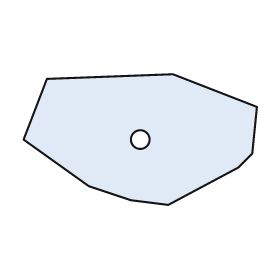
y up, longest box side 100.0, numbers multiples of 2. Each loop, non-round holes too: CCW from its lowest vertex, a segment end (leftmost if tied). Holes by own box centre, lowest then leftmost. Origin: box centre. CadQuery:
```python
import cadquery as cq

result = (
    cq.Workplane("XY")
    .moveTo(12.0, -28.0)
    .lineTo(42.0, -12.0)
    .lineTo(48.0, -6.0)
    .lineTo(50.0, 14.0)
    .lineTo(14.0, 28.0)
    .lineTo(-40.0, 26.0)
    .lineTo(-50.0, 0.0)
    .lineTo(-22.0, -20.0)
    .lineTo(-4.0, -26.0)
    .close()
    .moveTo(0.0, 0.0)
    .circle(4.0)
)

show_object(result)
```